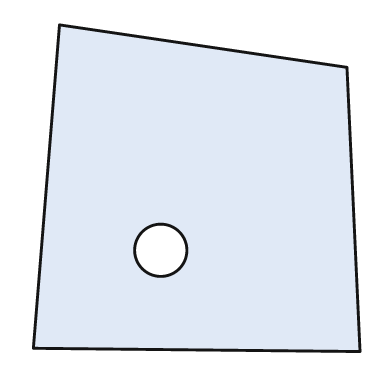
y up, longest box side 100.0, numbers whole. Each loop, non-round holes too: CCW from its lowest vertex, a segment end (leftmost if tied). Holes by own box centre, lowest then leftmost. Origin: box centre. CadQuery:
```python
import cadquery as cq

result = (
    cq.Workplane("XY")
    .moveTo(50.0, -50.0)
    .lineTo(46.0, 37.0)
    .lineTo(-42.0, 50.0)
    .lineTo(-50.0, -49.0)
    .close()
    .moveTo(-11.0, -19.0)
    .circle(8.0)
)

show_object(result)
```